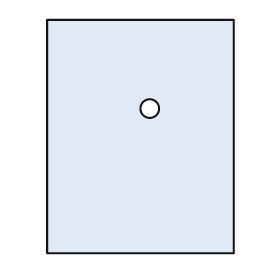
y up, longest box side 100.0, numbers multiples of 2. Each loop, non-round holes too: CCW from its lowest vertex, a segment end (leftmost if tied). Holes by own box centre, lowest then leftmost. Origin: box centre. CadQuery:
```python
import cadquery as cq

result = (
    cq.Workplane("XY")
    .moveTo(-40.0, -50.0)
    .lineTo(40.0, -50.0)
    .lineTo(40.0, 50.0)
    .lineTo(-40.0, 50.0)
    .close()
    .moveTo(4.0, 12.0)
    .circle(4.0)
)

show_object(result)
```